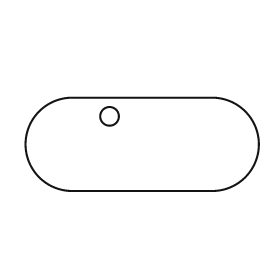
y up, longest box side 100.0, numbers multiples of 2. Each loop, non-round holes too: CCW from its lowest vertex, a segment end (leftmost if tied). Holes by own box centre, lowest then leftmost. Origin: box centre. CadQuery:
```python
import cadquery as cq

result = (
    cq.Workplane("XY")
    .moveTo(-30.0, -20.0)
    .lineTo(30.0, -20.0)
    .threePointArc((50.0, 0.0), (30.0, 20.0))
    .lineTo(-30.0, 20.0)
    .threePointArc((-50.0, 0.0), (-30.0, -20.0))
    .close()
    .moveTo(-14.0, 12.0)
    .circle(4.0)
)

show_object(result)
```